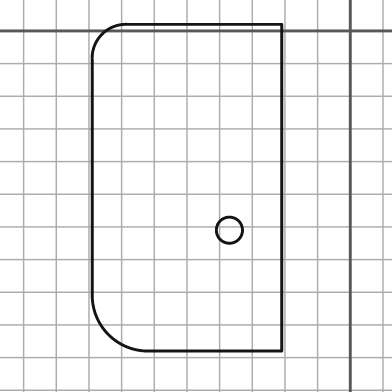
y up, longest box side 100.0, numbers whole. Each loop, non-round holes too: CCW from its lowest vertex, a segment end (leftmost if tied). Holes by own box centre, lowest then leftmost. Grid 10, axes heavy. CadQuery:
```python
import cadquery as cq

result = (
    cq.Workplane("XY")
    .moveTo(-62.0, -98.0)
    .lineTo(-21.0, -98.0)
    .lineTo(-21.0, 2.0)
    .lineTo(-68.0, 2.0)
    .threePointArc((-76.0, -1.0), (-79.0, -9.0))
    .lineTo(-79.0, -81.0)
    .threePointArc((-74.0, -93.0), (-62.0, -98.0))
    .close()
    .moveTo(-37.0, -61.0)
    .circle(4.0)
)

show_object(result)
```